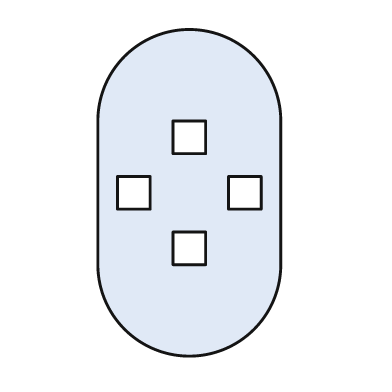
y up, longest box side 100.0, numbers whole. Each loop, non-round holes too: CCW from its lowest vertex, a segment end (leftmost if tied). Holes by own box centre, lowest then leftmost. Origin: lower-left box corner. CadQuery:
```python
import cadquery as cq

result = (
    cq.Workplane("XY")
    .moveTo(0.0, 28.0)
    .threePointArc((28.0, 0.0), (56.0, 28.0))
    .lineTo(56.0, 72.0)
    .threePointArc((28.0, 100.0), (0.0, 72.0))
    .close()
    .moveTo(23.0, 28.0)
    .lineTo(33.0, 28.0)
    .lineTo(33.0, 38.0)
    .lineTo(23.0, 38.0)
    .close()
    .moveTo(6.0, 45.0)
    .lineTo(16.0, 45.0)
    .lineTo(16.0, 55.0)
    .lineTo(6.0, 55.0)
    .close()
    .moveTo(40.0, 45.0)
    .lineTo(50.0, 45.0)
    .lineTo(50.0, 55.0)
    .lineTo(40.0, 55.0)
    .close()
    .moveTo(23.0, 62.0)
    .lineTo(33.0, 62.0)
    .lineTo(33.0, 72.0)
    .lineTo(23.0, 72.0)
    .close()
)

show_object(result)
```